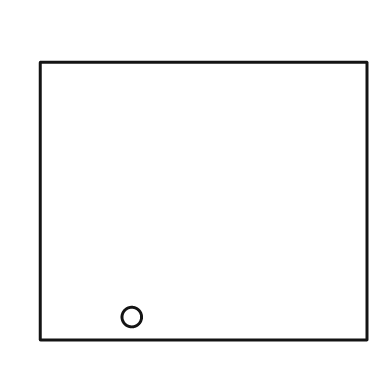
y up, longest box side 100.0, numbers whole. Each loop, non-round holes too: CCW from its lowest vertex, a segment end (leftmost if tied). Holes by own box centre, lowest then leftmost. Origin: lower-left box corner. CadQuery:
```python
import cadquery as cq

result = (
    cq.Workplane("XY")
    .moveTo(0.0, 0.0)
    .lineTo(100.0, 0.0)
    .lineTo(100.0, 85.0)
    .lineTo(0.0, 85.0)
    .close()
    .moveTo(28.0, 7.0)
    .circle(3.0)
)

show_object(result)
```